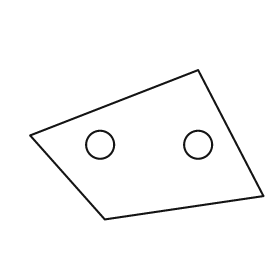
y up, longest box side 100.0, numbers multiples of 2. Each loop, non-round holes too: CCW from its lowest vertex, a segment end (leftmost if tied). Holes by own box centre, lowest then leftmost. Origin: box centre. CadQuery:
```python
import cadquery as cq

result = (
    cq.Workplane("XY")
    .moveTo(-18.0, -32.0)
    .lineTo(50.0, -22.0)
    .lineTo(22.0, 32.0)
    .lineTo(-50.0, 4.0)
    .close()
    .moveTo(-20.0, 0.0)
    .circle(6.0)
    .moveTo(22.0, 0.0)
    .circle(6.0)
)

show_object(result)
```